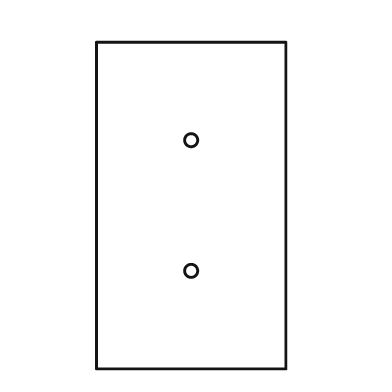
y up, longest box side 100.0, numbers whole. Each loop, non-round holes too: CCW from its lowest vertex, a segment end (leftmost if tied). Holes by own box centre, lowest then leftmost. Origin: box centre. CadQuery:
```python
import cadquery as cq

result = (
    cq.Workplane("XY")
    .moveTo(-29.0, -50.0)
    .lineTo(29.0, -50.0)
    .lineTo(29.0, 50.0)
    .lineTo(-29.0, 50.0)
    .close()
    .moveTo(0.0, -20.0)
    .circle(2.0)
    .moveTo(0.0, 20.0)
    .circle(2.0)
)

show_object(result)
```